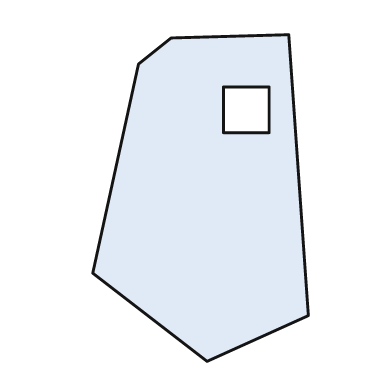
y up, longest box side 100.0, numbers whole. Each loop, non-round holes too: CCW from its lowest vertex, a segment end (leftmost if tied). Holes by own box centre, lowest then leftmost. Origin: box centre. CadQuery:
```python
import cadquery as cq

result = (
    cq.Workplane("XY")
    .moveTo(2.0, -50.0)
    .lineTo(33.0, -36.0)
    .lineTo(27.0, 50.0)
    .lineTo(-9.0, 49.0)
    .lineTo(-19.0, 41.0)
    .lineTo(-33.0, -23.0)
    .close()
    .moveTo(7.0, 20.0)
    .lineTo(21.0, 20.0)
    .lineTo(21.0, 34.0)
    .lineTo(7.0, 34.0)
    .close()
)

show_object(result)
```